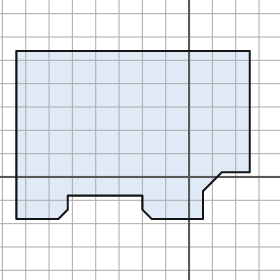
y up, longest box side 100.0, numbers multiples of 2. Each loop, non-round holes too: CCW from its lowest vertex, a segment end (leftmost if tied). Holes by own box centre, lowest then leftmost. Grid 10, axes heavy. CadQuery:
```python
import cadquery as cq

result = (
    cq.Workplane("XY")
    .moveTo(-74.0, -18.0)
    .lineTo(-56.0, -18.0)
    .lineTo(-52.0, -14.0)
    .lineTo(-52.0, -8.0)
    .lineTo(-20.0, -8.0)
    .lineTo(-20.0, -14.0)
    .lineTo(-16.0, -18.0)
    .lineTo(6.0, -18.0)
    .lineTo(6.0, -6.0)
    .lineTo(14.0, 2.0)
    .lineTo(26.0, 2.0)
    .lineTo(26.0, 54.0)
    .lineTo(-74.0, 54.0)
    .close()
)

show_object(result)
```